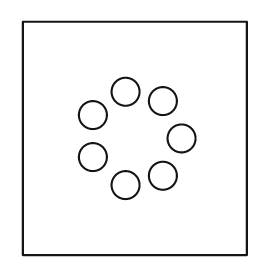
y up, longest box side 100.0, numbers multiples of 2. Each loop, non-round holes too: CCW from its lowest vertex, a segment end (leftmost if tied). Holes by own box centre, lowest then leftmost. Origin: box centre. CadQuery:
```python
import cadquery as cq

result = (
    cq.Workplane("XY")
    .moveTo(-48.0, -50.0)
    .lineTo(48.0, -50.0)
    .lineTo(48.0, 50.0)
    .lineTo(-48.0, 50.0)
    .close()
    .moveTo(-4.0, -20.0)
    .circle(6.0)
    .moveTo(12.0, -16.0)
    .circle(6.0)
    .moveTo(-18.0, -8.0)
    .circle(6.0)
    .moveTo(20.0, 0.0)
    .circle(6.0)
    .moveTo(-18.0, 10.0)
    .circle(6.0)
    .moveTo(12.0, 16.0)
    .circle(6.0)
    .moveTo(-4.0, 20.0)
    .circle(6.0)
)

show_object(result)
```